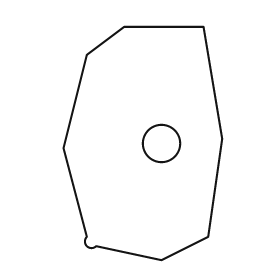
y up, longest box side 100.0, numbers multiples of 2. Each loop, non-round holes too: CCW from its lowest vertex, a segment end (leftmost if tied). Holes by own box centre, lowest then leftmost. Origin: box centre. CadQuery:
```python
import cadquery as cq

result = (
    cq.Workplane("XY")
    .moveTo(8.0, -50.0)
    .lineTo(28.0, -40.0)
    .lineTo(34.0, 2.0)
    .lineTo(26.0, 50.0)
    .lineTo(-8.0, 50.0)
    .lineTo(-24.0, 38.0)
    .lineTo(-34.0, -2.0)
    .lineTo(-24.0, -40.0)
    .threePointArc((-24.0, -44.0), (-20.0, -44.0))
    .close()
    .moveTo(8.0, 0.0)
    .circle(8.0)
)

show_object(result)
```